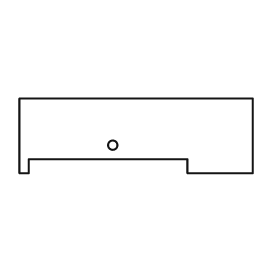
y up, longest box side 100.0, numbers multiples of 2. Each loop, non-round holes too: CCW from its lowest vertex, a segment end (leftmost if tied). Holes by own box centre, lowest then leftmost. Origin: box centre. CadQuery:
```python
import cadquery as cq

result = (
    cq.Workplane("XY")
    .moveTo(-50.0, -16.0)
    .lineTo(-46.0, -16.0)
    .lineTo(-46.0, -10.0)
    .lineTo(22.0, -10.0)
    .lineTo(22.0, -16.0)
    .lineTo(50.0, -16.0)
    .lineTo(50.0, 16.0)
    .lineTo(-50.0, 16.0)
    .close()
    .moveTo(-10.0, -4.0)
    .circle(2.0)
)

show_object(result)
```